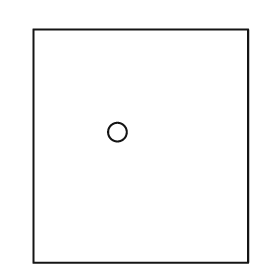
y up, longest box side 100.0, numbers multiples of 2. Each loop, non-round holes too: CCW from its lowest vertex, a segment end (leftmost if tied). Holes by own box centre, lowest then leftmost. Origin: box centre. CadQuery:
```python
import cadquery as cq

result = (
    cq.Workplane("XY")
    .moveTo(-46.0, -50.0)
    .lineTo(46.0, -50.0)
    .lineTo(46.0, 50.0)
    .lineTo(-46.0, 50.0)
    .close()
    .moveTo(-10.0, 6.0)
    .circle(4.0)
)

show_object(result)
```